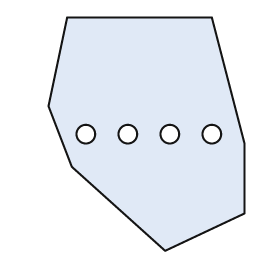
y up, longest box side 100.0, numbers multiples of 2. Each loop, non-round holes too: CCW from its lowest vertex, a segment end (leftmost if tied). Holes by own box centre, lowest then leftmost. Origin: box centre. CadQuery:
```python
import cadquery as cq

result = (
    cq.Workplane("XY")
    .moveTo(8.0, -50.0)
    .lineTo(42.0, -34.0)
    .lineTo(42.0, -4.0)
    .lineTo(28.0, 50.0)
    .lineTo(-34.0, 50.0)
    .lineTo(-42.0, 12.0)
    .lineTo(-32.0, -14.0)
    .close()
    .moveTo(-26.0, 0.0)
    .circle(4.0)
    .moveTo(-8.0, 0.0)
    .circle(4.0)
    .moveTo(10.0, 0.0)
    .circle(4.0)
    .moveTo(28.0, 0.0)
    .circle(4.0)
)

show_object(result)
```